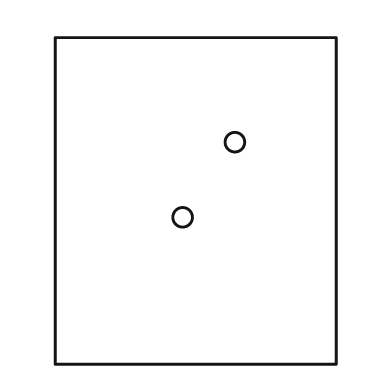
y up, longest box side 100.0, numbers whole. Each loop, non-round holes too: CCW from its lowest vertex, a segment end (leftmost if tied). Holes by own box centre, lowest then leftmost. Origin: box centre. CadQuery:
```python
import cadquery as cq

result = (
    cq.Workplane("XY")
    .moveTo(-43.0, -50.0)
    .lineTo(43.0, -50.0)
    .lineTo(43.0, 50.0)
    .lineTo(-43.0, 50.0)
    .close()
    .moveTo(-4.0, -5.0)
    .circle(3.0)
    .moveTo(12.0, 18.0)
    .circle(3.0)
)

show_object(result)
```